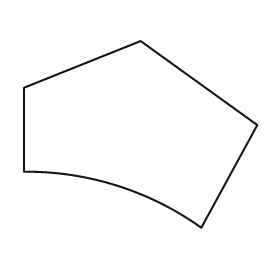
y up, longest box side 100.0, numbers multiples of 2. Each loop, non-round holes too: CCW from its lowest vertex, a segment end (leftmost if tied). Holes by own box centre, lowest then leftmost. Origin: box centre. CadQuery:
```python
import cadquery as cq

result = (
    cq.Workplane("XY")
    .moveTo(26.0, -40.0)
    .lineTo(50.0, 4.0)
    .lineTo(0.0, 40.0)
    .lineTo(-50.0, 20.0)
    .lineTo(-50.0, -16.0)
    .threePointArc((-10.0, -22.0), (26.0, -40.0))
    .close()
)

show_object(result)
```